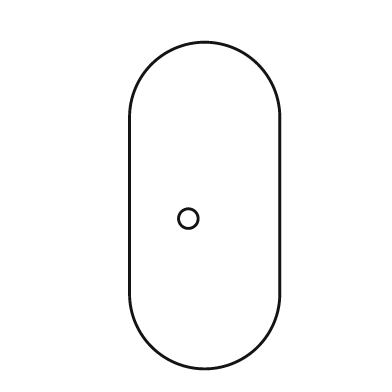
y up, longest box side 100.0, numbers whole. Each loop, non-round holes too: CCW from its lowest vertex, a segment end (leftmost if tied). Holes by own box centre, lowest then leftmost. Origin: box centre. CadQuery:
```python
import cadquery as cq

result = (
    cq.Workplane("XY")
    .moveTo(-23.0, -27.0)
    .threePointArc((0.0, -50.0), (23.0, -27.0))
    .lineTo(23.0, 27.0)
    .threePointArc((0.0, 50.0), (-23.0, 27.0))
    .close()
    .moveTo(-5.0, -4.0)
    .circle(3.0)
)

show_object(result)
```